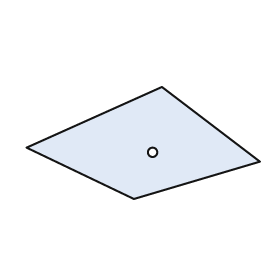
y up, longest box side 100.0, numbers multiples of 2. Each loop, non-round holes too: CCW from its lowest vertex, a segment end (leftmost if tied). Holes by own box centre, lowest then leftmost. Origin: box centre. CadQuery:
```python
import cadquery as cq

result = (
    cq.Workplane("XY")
    .moveTo(-4.0, -24.0)
    .lineTo(50.0, -8.0)
    .lineTo(8.0, 24.0)
    .lineTo(-50.0, -2.0)
    .close()
    .moveTo(4.0, -4.0)
    .circle(2.0)
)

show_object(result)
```